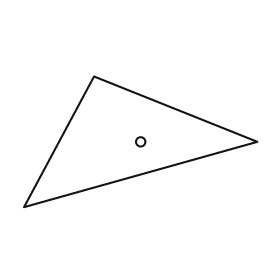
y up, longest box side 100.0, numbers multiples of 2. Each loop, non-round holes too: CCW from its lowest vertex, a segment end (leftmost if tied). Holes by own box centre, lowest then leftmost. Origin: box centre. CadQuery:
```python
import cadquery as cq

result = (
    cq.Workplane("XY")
    .moveTo(-50.0, -28.0)
    .lineTo(50.0, 0.0)
    .lineTo(-20.0, 28.0)
    .close()
    .moveTo(0.0, 0.0)
    .circle(2.0)
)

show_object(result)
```